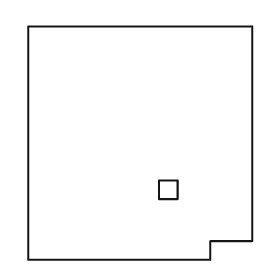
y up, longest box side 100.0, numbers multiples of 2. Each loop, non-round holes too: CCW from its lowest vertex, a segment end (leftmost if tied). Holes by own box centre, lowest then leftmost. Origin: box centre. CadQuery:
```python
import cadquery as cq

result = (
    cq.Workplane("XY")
    .moveTo(-48.0, -50.0)
    .lineTo(30.0, -50.0)
    .lineTo(30.0, -42.0)
    .lineTo(48.0, -42.0)
    .lineTo(48.0, 50.0)
    .lineTo(-48.0, 50.0)
    .close()
    .moveTo(8.0, -24.0)
    .lineTo(16.0, -24.0)
    .lineTo(16.0, -16.0)
    .lineTo(8.0, -16.0)
    .close()
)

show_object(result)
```